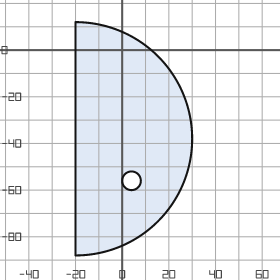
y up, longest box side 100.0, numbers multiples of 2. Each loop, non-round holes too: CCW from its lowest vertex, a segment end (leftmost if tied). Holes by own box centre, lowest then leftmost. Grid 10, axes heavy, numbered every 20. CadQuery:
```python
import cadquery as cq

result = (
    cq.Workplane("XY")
    .moveTo(-20.0, -88.0)
    .threePointArc((30.0, -38.0), (-20.0, 12.0))
    .close()
    .moveTo(4.0, -56.0)
    .circle(4.0)
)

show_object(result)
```